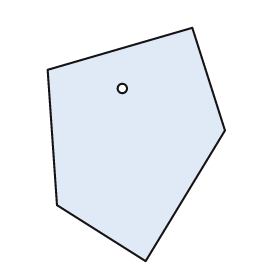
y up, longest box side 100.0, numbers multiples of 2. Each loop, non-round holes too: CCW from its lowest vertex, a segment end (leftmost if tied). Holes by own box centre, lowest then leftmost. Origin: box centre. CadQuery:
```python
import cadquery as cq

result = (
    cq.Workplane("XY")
    .moveTo(4.0, -50.0)
    .lineTo(38.0, 6.0)
    .lineTo(24.0, 50.0)
    .lineTo(-38.0, 32.0)
    .lineTo(-34.0, -26.0)
    .close()
    .moveTo(-6.0, 24.0)
    .circle(2.0)
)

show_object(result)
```